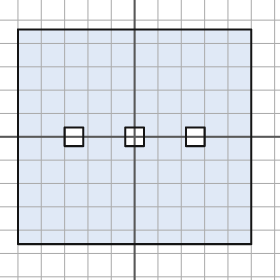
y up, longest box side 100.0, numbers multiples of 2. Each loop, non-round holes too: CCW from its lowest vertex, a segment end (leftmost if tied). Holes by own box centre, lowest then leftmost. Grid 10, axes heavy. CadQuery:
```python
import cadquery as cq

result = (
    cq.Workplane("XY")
    .moveTo(-50.0, -46.0)
    .lineTo(50.0, -46.0)
    .lineTo(50.0, 46.0)
    .lineTo(-50.0, 46.0)
    .close()
    .moveTo(-30.0, -4.0)
    .lineTo(-22.0, -4.0)
    .lineTo(-22.0, 4.0)
    .lineTo(-30.0, 4.0)
    .close()
    .moveTo(-4.0, -4.0)
    .lineTo(4.0, -4.0)
    .lineTo(4.0, 4.0)
    .lineTo(-4.0, 4.0)
    .close()
    .moveTo(22.0, -4.0)
    .lineTo(30.0, -4.0)
    .lineTo(30.0, 4.0)
    .lineTo(22.0, 4.0)
    .close()
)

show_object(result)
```